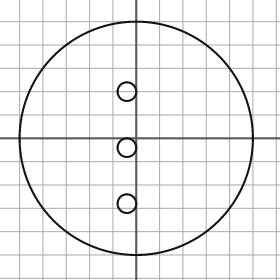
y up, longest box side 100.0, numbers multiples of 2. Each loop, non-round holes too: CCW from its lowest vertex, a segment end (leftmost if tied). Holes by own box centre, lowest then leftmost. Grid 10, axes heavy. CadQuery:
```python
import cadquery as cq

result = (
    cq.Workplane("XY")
    .moveTo(0.0, 0.0)
    .circle(50.0)
    .moveTo(-4.0, -28.0)
    .circle(4.0)
    .moveTo(-4.0, -4.0)
    .circle(4.0)
    .moveTo(-4.0, 20.0)
    .circle(4.0)
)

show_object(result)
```